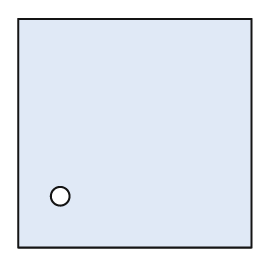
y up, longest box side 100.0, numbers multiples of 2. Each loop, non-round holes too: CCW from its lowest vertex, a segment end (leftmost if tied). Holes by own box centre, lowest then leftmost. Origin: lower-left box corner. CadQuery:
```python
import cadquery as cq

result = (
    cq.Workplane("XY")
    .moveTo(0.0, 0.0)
    .lineTo(100.0, 0.0)
    .lineTo(100.0, 98.0)
    .lineTo(0.0, 98.0)
    .close()
    .moveTo(18.0, 22.0)
    .circle(4.0)
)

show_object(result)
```